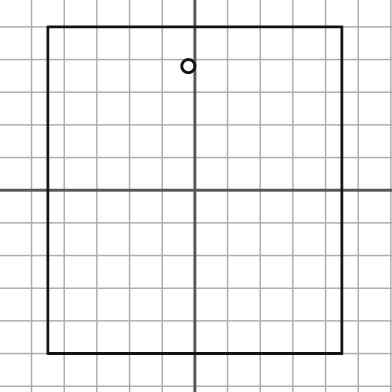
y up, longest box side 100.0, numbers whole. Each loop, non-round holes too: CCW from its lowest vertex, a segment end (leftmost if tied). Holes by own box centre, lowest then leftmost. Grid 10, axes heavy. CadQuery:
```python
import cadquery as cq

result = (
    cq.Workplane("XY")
    .moveTo(-45.0, -50.0)
    .lineTo(45.0, -50.0)
    .lineTo(45.0, 50.0)
    .lineTo(-45.0, 50.0)
    .close()
    .moveTo(-2.0, 38.0)
    .circle(2.0)
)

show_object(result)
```